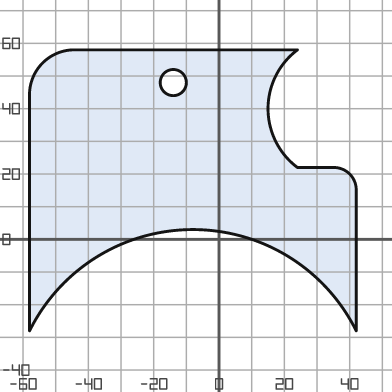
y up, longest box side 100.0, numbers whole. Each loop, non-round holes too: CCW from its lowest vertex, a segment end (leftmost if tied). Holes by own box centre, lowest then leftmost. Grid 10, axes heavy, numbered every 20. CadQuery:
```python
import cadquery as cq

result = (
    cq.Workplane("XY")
    .moveTo(-58.0, -28.0)
    .threePointArc((-8.0, 3.0), (42.0, -28.0))
    .lineTo(42.0, 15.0)
    .threePointArc((40.0, 20.0), (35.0, 22.0))
    .lineTo(24.0, 22.0)
    .threePointArc((15.0, 40.0), (24.0, 58.0))
    .lineTo(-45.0, 58.0)
    .threePointArc((-54.0, 54.0), (-58.0, 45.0))
    .close()
    .moveTo(-14.0, 48.0)
    .circle(4.0)
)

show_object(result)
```